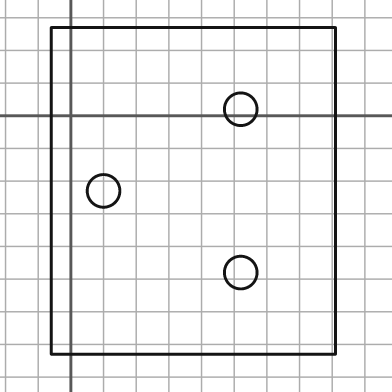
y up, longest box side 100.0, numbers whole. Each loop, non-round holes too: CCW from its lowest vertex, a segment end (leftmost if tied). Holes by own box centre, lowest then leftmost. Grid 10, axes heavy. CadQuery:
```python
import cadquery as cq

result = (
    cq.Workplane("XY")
    .moveTo(-6.0, -73.0)
    .lineTo(81.0, -73.0)
    .lineTo(81.0, 27.0)
    .lineTo(-6.0, 27.0)
    .close()
    .moveTo(52.0, -48.0)
    .circle(5.0)
    .moveTo(10.0, -23.0)
    .circle(5.0)
    .moveTo(52.0, 2.0)
    .circle(5.0)
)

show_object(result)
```